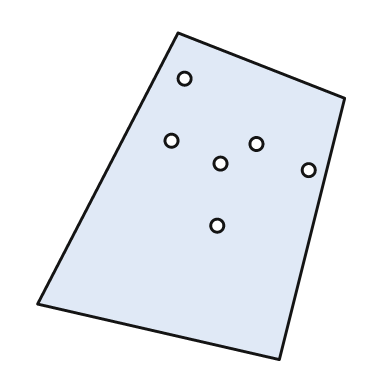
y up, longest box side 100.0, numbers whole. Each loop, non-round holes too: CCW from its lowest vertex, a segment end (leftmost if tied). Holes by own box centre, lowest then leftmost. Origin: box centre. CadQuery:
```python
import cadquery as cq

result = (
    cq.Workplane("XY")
    .moveTo(27.0, -50.0)
    .lineTo(47.0, 30.0)
    .lineTo(-4.0, 50.0)
    .lineTo(-47.0, -33.0)
    .close()
    .moveTo(8.0, -9.0)
    .circle(2.0)
    .moveTo(36.0, 8.0)
    .circle(2.0)
    .moveTo(9.0, 10.0)
    .circle(2.0)
    .moveTo(20.0, 16.0)
    .circle(2.0)
    .moveTo(-6.0, 17.0)
    .circle(2.0)
    .moveTo(-2.0, 36.0)
    .circle(2.0)
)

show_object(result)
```